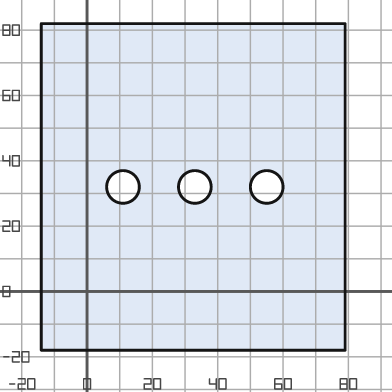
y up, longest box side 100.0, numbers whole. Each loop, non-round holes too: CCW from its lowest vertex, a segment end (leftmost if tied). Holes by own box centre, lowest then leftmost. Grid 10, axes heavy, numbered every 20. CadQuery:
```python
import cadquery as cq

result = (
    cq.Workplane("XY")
    .moveTo(-14.0, -18.0)
    .lineTo(79.0, -18.0)
    .lineTo(79.0, 82.0)
    .lineTo(-14.0, 82.0)
    .close()
    .moveTo(11.0, 32.0)
    .circle(5.0)
    .moveTo(33.0, 32.0)
    .circle(5.0)
    .moveTo(55.0, 32.0)
    .circle(5.0)
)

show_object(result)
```